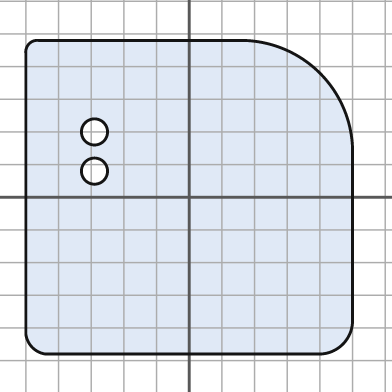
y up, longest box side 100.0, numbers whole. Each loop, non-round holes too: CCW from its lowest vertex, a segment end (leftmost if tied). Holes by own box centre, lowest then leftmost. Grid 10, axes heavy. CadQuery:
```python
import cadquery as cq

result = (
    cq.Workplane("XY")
    .moveTo(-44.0, -48.0)
    .lineTo(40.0, -48.0)
    .threePointArc((47.0, -45.0), (50.0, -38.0))
    .lineTo(50.0, 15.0)
    .threePointArc((40.0, 38.0), (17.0, 48.0))
    .lineTo(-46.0, 48.0)
    .threePointArc((-49.0, 47.0), (-50.0, 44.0))
    .lineTo(-50.0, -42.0)
    .threePointArc((-48.0, -46.0), (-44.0, -48.0))
    .close()
    .moveTo(-29.0, 8.0)
    .circle(4.0)
    .moveTo(-29.0, 20.0)
    .circle(4.0)
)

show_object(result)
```